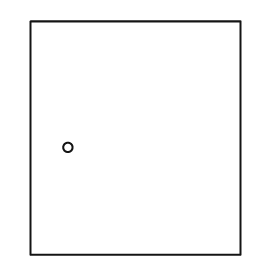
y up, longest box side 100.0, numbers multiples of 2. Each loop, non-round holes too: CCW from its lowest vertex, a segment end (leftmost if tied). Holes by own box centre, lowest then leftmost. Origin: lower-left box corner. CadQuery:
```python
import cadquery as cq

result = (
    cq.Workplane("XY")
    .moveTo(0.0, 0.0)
    .lineTo(90.0, 0.0)
    .lineTo(90.0, 100.0)
    .lineTo(0.0, 100.0)
    .close()
    .moveTo(16.0, 46.0)
    .circle(2.0)
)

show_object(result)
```